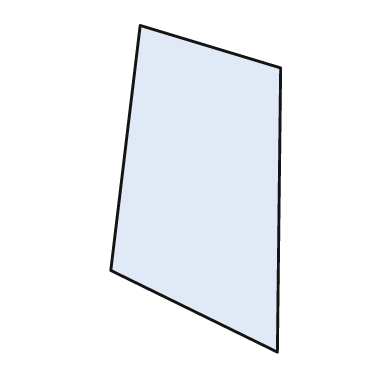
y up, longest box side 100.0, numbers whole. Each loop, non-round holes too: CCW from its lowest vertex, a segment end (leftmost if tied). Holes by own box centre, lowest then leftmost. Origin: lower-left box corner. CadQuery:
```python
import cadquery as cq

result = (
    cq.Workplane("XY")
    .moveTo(51.0, 0.0)
    .lineTo(52.0, 87.0)
    .lineTo(9.0, 100.0)
    .lineTo(0.0, 25.0)
    .close()
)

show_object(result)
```